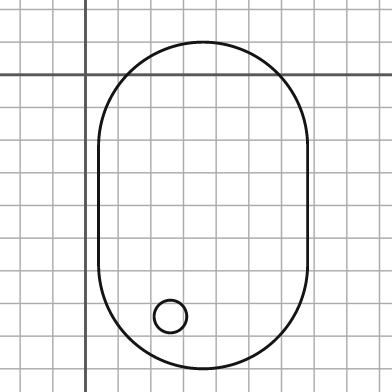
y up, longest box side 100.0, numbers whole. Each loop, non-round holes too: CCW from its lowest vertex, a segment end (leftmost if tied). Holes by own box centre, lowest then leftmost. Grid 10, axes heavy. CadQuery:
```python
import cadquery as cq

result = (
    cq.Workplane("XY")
    .moveTo(4.0, -58.0)
    .threePointArc((36.0, -90.0), (68.0, -58.0))
    .lineTo(68.0, -22.0)
    .threePointArc((36.0, 10.0), (4.0, -22.0))
    .close()
    .moveTo(26.0, -74.0)
    .circle(5.0)
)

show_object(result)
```